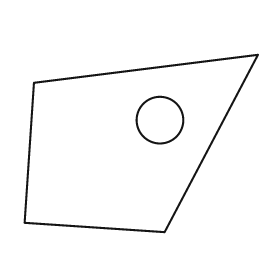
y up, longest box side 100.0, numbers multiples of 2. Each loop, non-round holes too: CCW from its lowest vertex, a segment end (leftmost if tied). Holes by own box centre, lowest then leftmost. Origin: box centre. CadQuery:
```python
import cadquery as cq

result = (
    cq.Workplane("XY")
    .moveTo(10.0, -38.0)
    .lineTo(50.0, 38.0)
    .lineTo(-46.0, 26.0)
    .lineTo(-50.0, -34.0)
    .close()
    .moveTo(8.0, 10.0)
    .circle(10.0)
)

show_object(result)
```